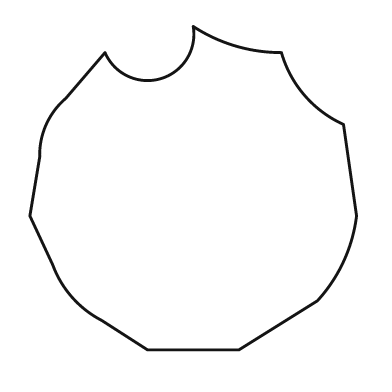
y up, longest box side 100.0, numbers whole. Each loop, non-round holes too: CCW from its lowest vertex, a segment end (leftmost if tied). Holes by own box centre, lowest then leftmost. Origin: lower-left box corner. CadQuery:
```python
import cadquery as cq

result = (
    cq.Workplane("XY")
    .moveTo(36.0, 0.0)
    .lineTo(64.0, 0.0)
    .lineTo(88.0, 15.0)
    .threePointArc((96.0, 27.0), (100.0, 41.0))
    .lineTo(96.0, 69.0)
    .threePointArc((84.0, 78.0), (77.0, 91.0))
    .threePointArc((63.0, 93.0), (50.0, 99.0))
    .threePointArc((40.0, 83.0), (23.0, 91.0))
    .lineTo(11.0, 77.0)
    .threePointArc((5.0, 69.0), (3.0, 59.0))
    .lineTo(0.0, 41.0)
    .lineTo(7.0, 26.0)
    .threePointArc((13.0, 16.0), (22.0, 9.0))
    .close()
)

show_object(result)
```